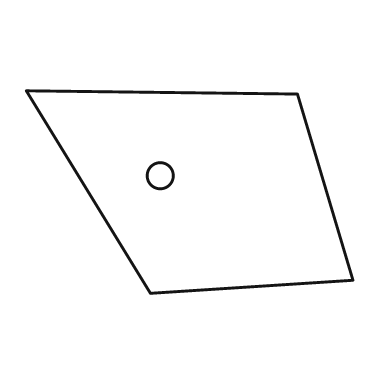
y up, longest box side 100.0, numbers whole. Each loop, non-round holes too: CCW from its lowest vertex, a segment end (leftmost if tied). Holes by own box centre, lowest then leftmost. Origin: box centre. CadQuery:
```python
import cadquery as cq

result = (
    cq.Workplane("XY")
    .moveTo(-12.0, -31.0)
    .lineTo(50.0, -27.0)
    .lineTo(33.0, 30.0)
    .lineTo(-50.0, 31.0)
    .close()
    .moveTo(-9.0, 5.0)
    .circle(4.0)
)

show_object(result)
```